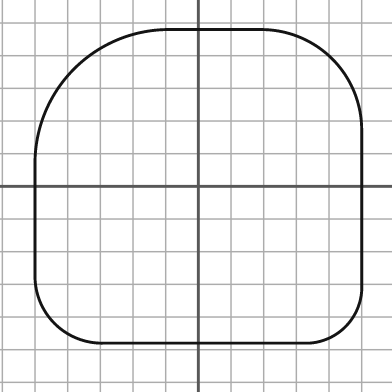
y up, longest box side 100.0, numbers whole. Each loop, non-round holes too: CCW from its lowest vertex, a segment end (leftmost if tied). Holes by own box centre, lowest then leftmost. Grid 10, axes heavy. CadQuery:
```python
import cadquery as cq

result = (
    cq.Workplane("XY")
    .moveTo(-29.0, -48.0)
    .lineTo(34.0, -48.0)
    .threePointArc((45.0, -43.0), (50.0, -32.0))
    .lineTo(50.0, 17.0)
    .threePointArc((41.0, 39.0), (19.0, 48.0))
    .lineTo(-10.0, 48.0)
    .threePointArc((-38.0, 36.0), (-50.0, 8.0))
    .lineTo(-50.0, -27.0)
    .threePointArc((-44.0, -42.0), (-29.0, -48.0))
    .close()
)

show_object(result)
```